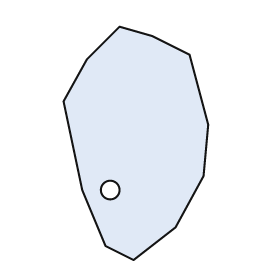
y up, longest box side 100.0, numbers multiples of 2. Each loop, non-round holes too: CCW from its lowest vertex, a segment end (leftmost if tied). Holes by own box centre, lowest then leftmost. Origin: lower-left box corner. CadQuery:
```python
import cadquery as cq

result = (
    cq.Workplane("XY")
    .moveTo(30.0, 0.0)
    .lineTo(48.0, 14.0)
    .lineTo(60.0, 36.0)
    .lineTo(62.0, 58.0)
    .lineTo(54.0, 88.0)
    .lineTo(38.0, 96.0)
    .lineTo(24.0, 100.0)
    .lineTo(10.0, 86.0)
    .lineTo(0.0, 68.0)
    .lineTo(8.0, 30.0)
    .lineTo(18.0, 6.0)
    .close()
    .moveTo(20.0, 30.0)
    .circle(4.0)
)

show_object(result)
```